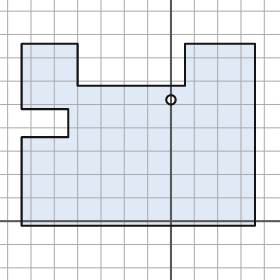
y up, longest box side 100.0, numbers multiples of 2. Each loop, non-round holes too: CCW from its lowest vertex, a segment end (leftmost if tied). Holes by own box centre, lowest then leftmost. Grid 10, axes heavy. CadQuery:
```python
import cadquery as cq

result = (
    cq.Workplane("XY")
    .moveTo(-64.0, -2.0)
    .lineTo(36.0, -2.0)
    .lineTo(36.0, 76.0)
    .lineTo(6.0, 76.0)
    .lineTo(6.0, 58.0)
    .lineTo(-40.0, 58.0)
    .lineTo(-40.0, 76.0)
    .lineTo(-64.0, 76.0)
    .lineTo(-64.0, 48.0)
    .lineTo(-44.0, 48.0)
    .lineTo(-44.0, 36.0)
    .lineTo(-64.0, 36.0)
    .close()
    .moveTo(0.0, 52.0)
    .circle(2.0)
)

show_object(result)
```